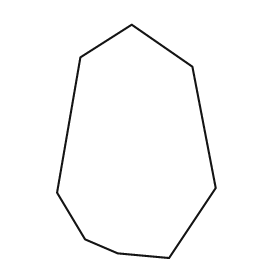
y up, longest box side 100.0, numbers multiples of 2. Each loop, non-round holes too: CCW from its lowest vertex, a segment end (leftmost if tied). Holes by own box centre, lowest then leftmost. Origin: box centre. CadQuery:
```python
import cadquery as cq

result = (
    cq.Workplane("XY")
    .moveTo(14.0, -50.0)
    .lineTo(34.0, -20.0)
    .lineTo(24.0, 32.0)
    .lineTo(-2.0, 50.0)
    .lineTo(-24.0, 36.0)
    .lineTo(-34.0, -22.0)
    .lineTo(-22.0, -42.0)
    .lineTo(-8.0, -48.0)
    .close()
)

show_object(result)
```